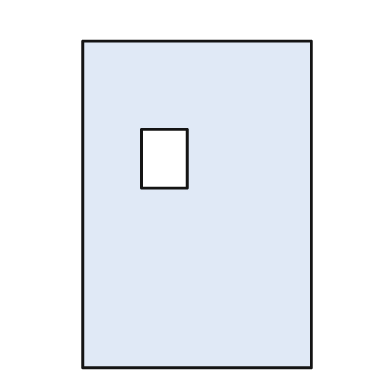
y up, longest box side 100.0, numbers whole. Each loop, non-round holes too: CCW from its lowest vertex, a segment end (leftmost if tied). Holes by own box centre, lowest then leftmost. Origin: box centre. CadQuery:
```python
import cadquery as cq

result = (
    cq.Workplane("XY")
    .moveTo(-35.0, -50.0)
    .lineTo(35.0, -50.0)
    .lineTo(35.0, 50.0)
    .lineTo(-35.0, 50.0)
    .close()
    .moveTo(-17.0, 5.0)
    .lineTo(-3.0, 5.0)
    .lineTo(-3.0, 23.0)
    .lineTo(-17.0, 23.0)
    .close()
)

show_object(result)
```